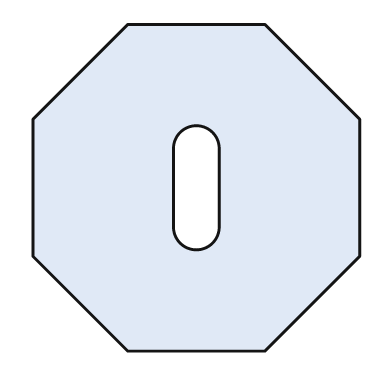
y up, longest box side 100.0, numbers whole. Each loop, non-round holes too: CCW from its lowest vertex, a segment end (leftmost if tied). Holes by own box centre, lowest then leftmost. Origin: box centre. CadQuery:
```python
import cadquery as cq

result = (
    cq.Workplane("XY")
    .moveTo(-21.0, -50.0)
    .lineTo(21.0, -50.0)
    .lineTo(50.0, -21.0)
    .lineTo(50.0, 21.0)
    .lineTo(21.0, 50.0)
    .lineTo(-21.0, 50.0)
    .lineTo(-50.0, 21.0)
    .lineTo(-50.0, -21.0)
    .close()
    .moveTo(-7.0, -12.0)
    .threePointArc((0.0, -19.0), (7.0, -12.0))
    .lineTo(7.0, 12.0)
    .threePointArc((0.0, 19.0), (-7.0, 12.0))
    .close()
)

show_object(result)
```